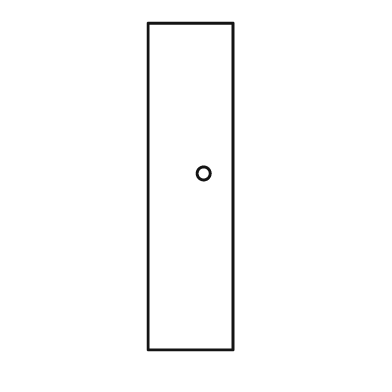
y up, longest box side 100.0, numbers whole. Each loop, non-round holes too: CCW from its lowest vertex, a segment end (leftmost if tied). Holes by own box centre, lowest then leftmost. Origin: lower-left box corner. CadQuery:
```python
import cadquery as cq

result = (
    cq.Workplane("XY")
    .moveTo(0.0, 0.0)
    .lineTo(26.0, 0.0)
    .lineTo(26.0, 100.0)
    .lineTo(0.0, 100.0)
    .close()
    .moveTo(17.0, 54.0)
    .circle(2.0)
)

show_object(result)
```